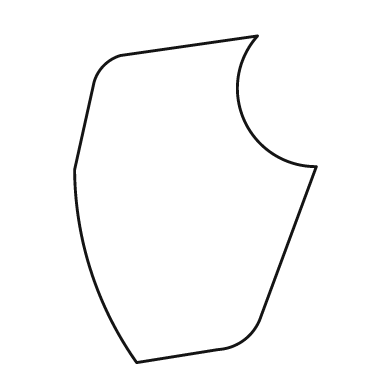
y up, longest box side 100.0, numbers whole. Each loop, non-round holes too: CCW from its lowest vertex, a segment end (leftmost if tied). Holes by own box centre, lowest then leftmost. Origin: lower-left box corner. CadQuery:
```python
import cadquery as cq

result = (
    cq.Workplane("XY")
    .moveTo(19.0, 0.0)
    .lineTo(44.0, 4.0)
    .threePointArc((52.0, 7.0), (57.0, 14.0))
    .lineTo(74.0, 60.0)
    .threePointArc((52.0, 74.0), (56.0, 100.0))
    .lineTo(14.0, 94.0)
    .threePointArc((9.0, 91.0), (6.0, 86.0))
    .lineTo(0.0, 59.0)
    .threePointArc((5.0, 28.0), (19.0, 0.0))
    .close()
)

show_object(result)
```